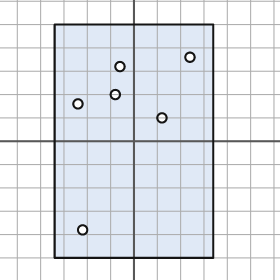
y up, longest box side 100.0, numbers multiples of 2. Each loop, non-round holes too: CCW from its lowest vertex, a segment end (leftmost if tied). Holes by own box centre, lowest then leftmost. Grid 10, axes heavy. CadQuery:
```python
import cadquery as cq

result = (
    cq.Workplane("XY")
    .moveTo(-34.0, -50.0)
    .lineTo(34.0, -50.0)
    .lineTo(34.0, 50.0)
    .lineTo(-34.0, 50.0)
    .close()
    .moveTo(-22.0, -38.0)
    .circle(2.0)
    .moveTo(12.0, 10.0)
    .circle(2.0)
    .moveTo(-24.0, 16.0)
    .circle(2.0)
    .moveTo(-8.0, 20.0)
    .circle(2.0)
    .moveTo(-6.0, 32.0)
    .circle(2.0)
    .moveTo(24.0, 36.0)
    .circle(2.0)
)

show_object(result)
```